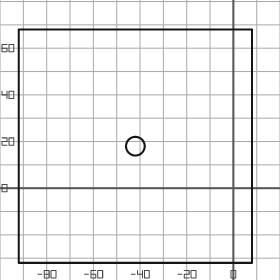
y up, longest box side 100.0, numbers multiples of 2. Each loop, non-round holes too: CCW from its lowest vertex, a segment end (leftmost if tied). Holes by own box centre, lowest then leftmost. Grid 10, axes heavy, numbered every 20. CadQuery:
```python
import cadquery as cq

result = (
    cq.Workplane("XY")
    .moveTo(-92.0, -32.0)
    .lineTo(8.0, -32.0)
    .lineTo(8.0, 68.0)
    .lineTo(-92.0, 68.0)
    .close()
    .moveTo(-42.0, 18.0)
    .circle(4.0)
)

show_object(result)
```